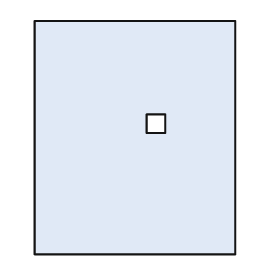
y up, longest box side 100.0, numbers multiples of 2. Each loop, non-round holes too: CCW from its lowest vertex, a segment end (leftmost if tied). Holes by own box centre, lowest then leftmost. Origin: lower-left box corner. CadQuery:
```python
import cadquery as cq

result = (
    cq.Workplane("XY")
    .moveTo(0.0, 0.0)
    .lineTo(86.0, 0.0)
    .lineTo(86.0, 100.0)
    .lineTo(0.0, 100.0)
    .close()
    .moveTo(48.0, 52.0)
    .lineTo(56.0, 52.0)
    .lineTo(56.0, 60.0)
    .lineTo(48.0, 60.0)
    .close()
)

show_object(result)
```